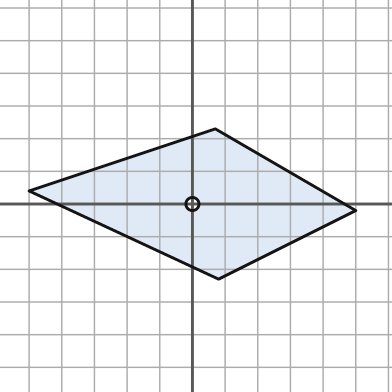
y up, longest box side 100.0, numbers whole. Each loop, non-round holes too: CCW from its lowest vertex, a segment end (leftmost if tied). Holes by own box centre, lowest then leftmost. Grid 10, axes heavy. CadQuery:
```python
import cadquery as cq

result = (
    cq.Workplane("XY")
    .moveTo(8.0, -23.0)
    .lineTo(50.0, -2.0)
    .lineTo(7.0, 23.0)
    .lineTo(-50.0, 4.0)
    .close()
    .moveTo(0.0, 0.0)
    .circle(2.0)
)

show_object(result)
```